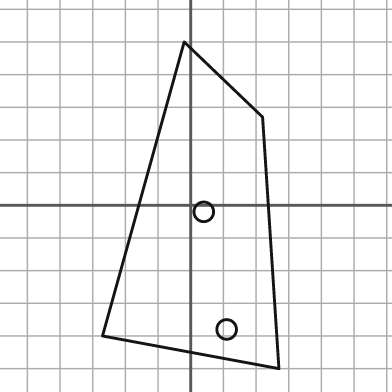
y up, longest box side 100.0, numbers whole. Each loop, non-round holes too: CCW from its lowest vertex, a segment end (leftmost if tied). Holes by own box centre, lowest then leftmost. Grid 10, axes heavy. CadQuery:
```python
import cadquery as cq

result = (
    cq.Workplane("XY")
    .moveTo(27.0, -50.0)
    .lineTo(22.0, 27.0)
    .lineTo(-2.0, 50.0)
    .lineTo(-27.0, -40.0)
    .close()
    .moveTo(11.0, -38.0)
    .circle(3.0)
    .moveTo(4.0, -2.0)
    .circle(3.0)
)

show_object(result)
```